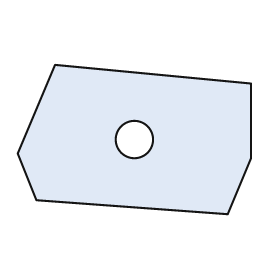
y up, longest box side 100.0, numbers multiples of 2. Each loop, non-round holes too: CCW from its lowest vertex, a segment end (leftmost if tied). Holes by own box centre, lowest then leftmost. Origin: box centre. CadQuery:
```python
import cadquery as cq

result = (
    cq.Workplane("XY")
    .moveTo(40.0, -32.0)
    .lineTo(50.0, -8.0)
    .lineTo(50.0, 24.0)
    .lineTo(-34.0, 32.0)
    .lineTo(-50.0, -6.0)
    .lineTo(-42.0, -26.0)
    .close()
    .moveTo(0.0, 0.0)
    .circle(8.0)
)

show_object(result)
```